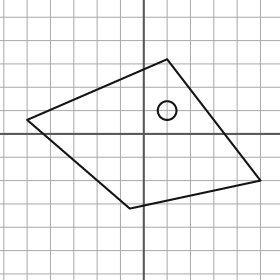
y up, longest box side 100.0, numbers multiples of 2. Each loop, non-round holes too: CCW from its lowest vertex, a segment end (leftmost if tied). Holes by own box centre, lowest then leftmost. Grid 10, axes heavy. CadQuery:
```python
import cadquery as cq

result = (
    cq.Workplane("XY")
    .moveTo(-6.0, -32.0)
    .lineTo(50.0, -20.0)
    .lineTo(10.0, 32.0)
    .lineTo(-50.0, 6.0)
    .close()
    .moveTo(10.0, 10.0)
    .circle(4.0)
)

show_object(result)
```